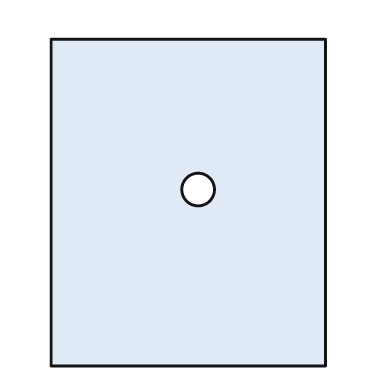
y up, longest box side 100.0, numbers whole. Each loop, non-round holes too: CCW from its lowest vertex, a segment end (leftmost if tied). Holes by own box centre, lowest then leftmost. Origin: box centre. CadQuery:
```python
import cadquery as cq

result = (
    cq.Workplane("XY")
    .moveTo(-42.0, -50.0)
    .lineTo(42.0, -50.0)
    .lineTo(42.0, 50.0)
    .lineTo(-42.0, 50.0)
    .close()
    .moveTo(3.0, 4.0)
    .circle(5.0)
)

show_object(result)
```